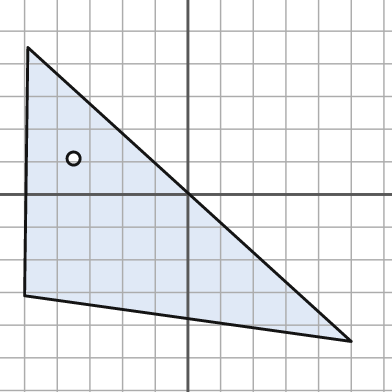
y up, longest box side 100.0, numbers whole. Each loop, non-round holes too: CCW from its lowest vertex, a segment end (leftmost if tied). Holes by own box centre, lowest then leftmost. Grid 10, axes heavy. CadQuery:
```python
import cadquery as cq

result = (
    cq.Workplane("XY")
    .moveTo(50.0, -45.0)
    .lineTo(-49.0, 45.0)
    .lineTo(-50.0, -31.0)
    .close()
    .moveTo(-35.0, 11.0)
    .circle(2.0)
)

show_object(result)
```